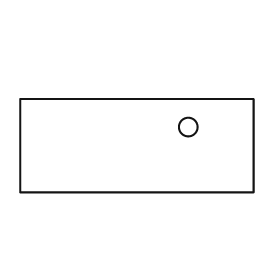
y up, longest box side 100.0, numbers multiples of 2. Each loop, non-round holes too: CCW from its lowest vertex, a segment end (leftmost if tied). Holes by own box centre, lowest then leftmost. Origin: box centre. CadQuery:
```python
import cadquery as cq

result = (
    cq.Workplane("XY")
    .moveTo(-50.0, -20.0)
    .lineTo(50.0, -20.0)
    .lineTo(50.0, 20.0)
    .lineTo(-50.0, 20.0)
    .close()
    .moveTo(22.0, 8.0)
    .circle(4.0)
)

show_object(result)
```